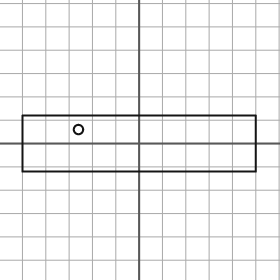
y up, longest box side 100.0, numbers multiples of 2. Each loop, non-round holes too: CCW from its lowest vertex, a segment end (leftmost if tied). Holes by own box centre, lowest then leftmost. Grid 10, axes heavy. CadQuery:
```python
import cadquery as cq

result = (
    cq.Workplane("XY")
    .moveTo(-50.0, -12.0)
    .lineTo(50.0, -12.0)
    .lineTo(50.0, 12.0)
    .lineTo(-50.0, 12.0)
    .close()
    .moveTo(-26.0, 6.0)
    .circle(2.0)
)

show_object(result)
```